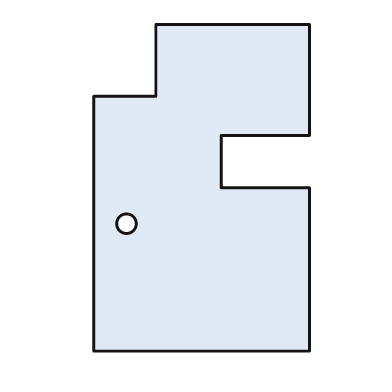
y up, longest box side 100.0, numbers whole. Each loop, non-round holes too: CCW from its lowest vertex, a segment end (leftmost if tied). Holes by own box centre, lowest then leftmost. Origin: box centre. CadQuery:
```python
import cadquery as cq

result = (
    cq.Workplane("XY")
    .moveTo(-33.0, -50.0)
    .lineTo(33.0, -50.0)
    .lineTo(33.0, 0.0)
    .lineTo(6.0, 0.0)
    .lineTo(6.0, 16.0)
    .lineTo(33.0, 16.0)
    .lineTo(33.0, 50.0)
    .lineTo(-14.0, 50.0)
    .lineTo(-14.0, 28.0)
    .lineTo(-33.0, 28.0)
    .close()
    .moveTo(-23.0, -11.0)
    .circle(3.0)
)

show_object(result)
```